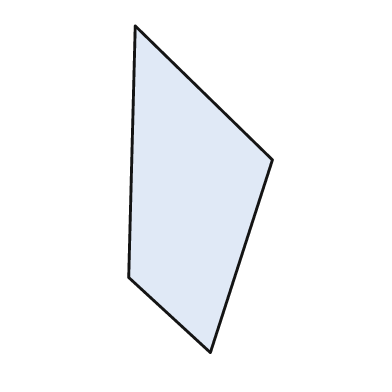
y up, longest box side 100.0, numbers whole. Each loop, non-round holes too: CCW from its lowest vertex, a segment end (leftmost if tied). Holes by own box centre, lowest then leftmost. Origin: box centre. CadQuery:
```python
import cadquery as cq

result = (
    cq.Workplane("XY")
    .moveTo(3.0, -50.0)
    .lineTo(22.0, 9.0)
    .lineTo(-20.0, 50.0)
    .lineTo(-22.0, -27.0)
    .close()
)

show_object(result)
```